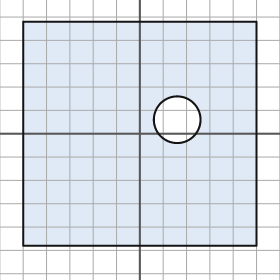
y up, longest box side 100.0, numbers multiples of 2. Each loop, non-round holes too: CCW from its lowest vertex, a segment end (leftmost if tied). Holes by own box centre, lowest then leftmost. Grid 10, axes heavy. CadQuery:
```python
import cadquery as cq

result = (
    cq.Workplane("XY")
    .moveTo(-50.0, -48.0)
    .lineTo(50.0, -48.0)
    .lineTo(50.0, 48.0)
    .lineTo(-50.0, 48.0)
    .close()
    .moveTo(16.0, 6.0)
    .circle(10.0)
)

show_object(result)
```